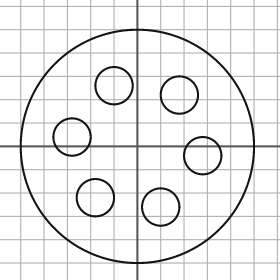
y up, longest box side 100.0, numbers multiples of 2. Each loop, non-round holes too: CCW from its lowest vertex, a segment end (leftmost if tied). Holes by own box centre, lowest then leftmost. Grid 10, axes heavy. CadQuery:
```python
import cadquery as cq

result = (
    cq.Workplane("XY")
    .moveTo(0.0, 0.0)
    .circle(50.0)
    .moveTo(10.0, -26.0)
    .circle(8.0)
    .moveTo(-18.0, -22.0)
    .circle(8.0)
    .moveTo(28.0, -4.0)
    .circle(8.0)
    .moveTo(-28.0, 4.0)
    .circle(8.0)
    .moveTo(18.0, 22.0)
    .circle(8.0)
    .moveTo(-10.0, 26.0)
    .circle(8.0)
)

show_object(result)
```